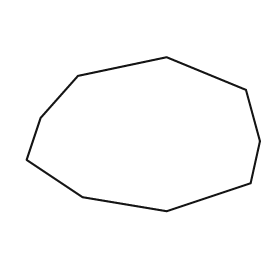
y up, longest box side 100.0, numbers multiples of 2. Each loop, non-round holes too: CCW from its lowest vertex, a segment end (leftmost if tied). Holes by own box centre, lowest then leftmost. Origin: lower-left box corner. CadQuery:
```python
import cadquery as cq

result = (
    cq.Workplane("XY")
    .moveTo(60.0, 0.0)
    .lineTo(96.0, 12.0)
    .lineTo(100.0, 30.0)
    .lineTo(94.0, 52.0)
    .lineTo(60.0, 66.0)
    .lineTo(22.0, 58.0)
    .lineTo(6.0, 40.0)
    .lineTo(0.0, 22.0)
    .lineTo(24.0, 6.0)
    .close()
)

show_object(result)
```